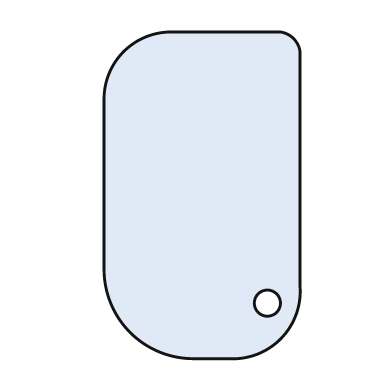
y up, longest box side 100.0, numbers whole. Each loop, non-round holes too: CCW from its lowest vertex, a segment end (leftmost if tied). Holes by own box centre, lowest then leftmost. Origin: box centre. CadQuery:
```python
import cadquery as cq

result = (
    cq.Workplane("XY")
    .moveTo(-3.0, -50.0)
    .lineTo(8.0, -50.0)
    .threePointArc((24.0, -44.0), (30.0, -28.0))
    .lineTo(30.0, 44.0)
    .threePointArc((28.0, 48.0), (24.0, 50.0))
    .lineTo(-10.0, 50.0)
    .threePointArc((-24.0, 44.0), (-30.0, 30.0))
    .lineTo(-30.0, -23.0)
    .threePointArc((-22.0, -42.0), (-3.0, -50.0))
    .close()
    .moveTo(20.0, -33.0)
    .circle(4.0)
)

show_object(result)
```